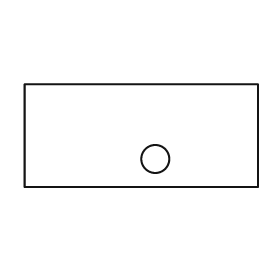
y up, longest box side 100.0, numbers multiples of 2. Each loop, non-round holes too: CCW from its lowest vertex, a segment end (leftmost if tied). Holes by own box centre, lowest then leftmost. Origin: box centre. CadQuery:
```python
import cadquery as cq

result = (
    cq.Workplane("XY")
    .moveTo(-50.0, -22.0)
    .lineTo(50.0, -22.0)
    .lineTo(50.0, 22.0)
    .lineTo(-50.0, 22.0)
    .close()
    .moveTo(6.0, -10.0)
    .circle(6.0)
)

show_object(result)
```